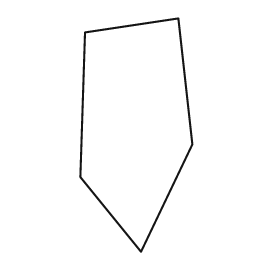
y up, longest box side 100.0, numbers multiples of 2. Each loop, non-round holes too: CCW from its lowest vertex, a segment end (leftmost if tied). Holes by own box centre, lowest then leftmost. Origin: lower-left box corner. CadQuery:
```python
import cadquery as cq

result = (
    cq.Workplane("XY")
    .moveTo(26.0, 0.0)
    .lineTo(48.0, 46.0)
    .lineTo(42.0, 100.0)
    .lineTo(2.0, 94.0)
    .lineTo(0.0, 32.0)
    .close()
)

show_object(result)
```